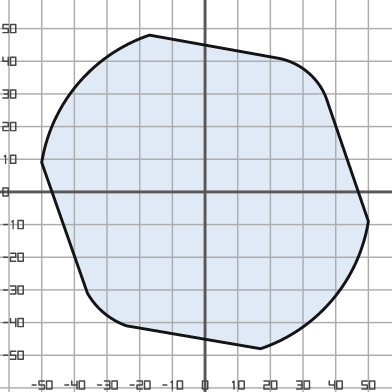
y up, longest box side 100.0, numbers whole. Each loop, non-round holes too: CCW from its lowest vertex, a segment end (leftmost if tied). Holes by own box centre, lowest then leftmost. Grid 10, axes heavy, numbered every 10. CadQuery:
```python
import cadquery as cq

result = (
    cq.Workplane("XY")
    .moveTo(17.0, -48.0)
    .threePointArc((39.0, -33.0), (50.0, -9.0))
    .lineTo(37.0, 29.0)
    .threePointArc((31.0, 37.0), (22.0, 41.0))
    .lineTo(-17.0, 48.0)
    .threePointArc((-39.0, 33.0), (-50.0, 9.0))
    .lineTo(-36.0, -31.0)
    .threePointArc((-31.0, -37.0), (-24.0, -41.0))
    .close()
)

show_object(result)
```